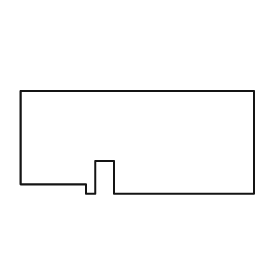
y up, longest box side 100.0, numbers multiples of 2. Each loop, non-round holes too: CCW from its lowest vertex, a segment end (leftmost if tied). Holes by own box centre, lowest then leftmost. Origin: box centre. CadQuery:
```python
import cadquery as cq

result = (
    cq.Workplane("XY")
    .moveTo(-22.0, -22.0)
    .lineTo(-18.0, -22.0)
    .lineTo(-18.0, -8.0)
    .lineTo(-10.0, -8.0)
    .lineTo(-10.0, -22.0)
    .lineTo(50.0, -22.0)
    .lineTo(50.0, 22.0)
    .lineTo(-50.0, 22.0)
    .lineTo(-50.0, -18.0)
    .lineTo(-22.0, -18.0)
    .close()
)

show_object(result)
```